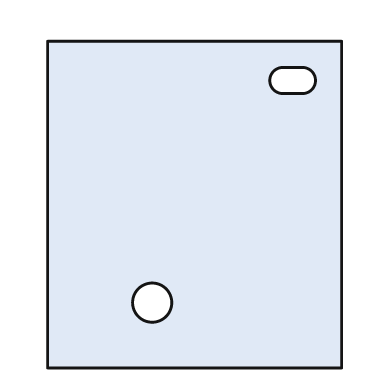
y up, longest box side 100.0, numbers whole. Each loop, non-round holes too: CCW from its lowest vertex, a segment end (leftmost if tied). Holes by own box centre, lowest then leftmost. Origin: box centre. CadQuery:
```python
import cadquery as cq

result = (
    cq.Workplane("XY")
    .moveTo(-45.0, -50.0)
    .lineTo(45.0, -50.0)
    .lineTo(45.0, 50.0)
    .lineTo(-45.0, 50.0)
    .close()
    .moveTo(-13.0, -30.0)
    .circle(6.0)
    .moveTo(27.0, 34.0)
    .lineTo(33.0, 34.0)
    .threePointArc((37.0, 38.0), (33.0, 42.0))
    .lineTo(27.0, 42.0)
    .threePointArc((23.0, 38.0), (27.0, 34.0))
    .close()
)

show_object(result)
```